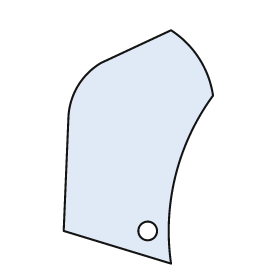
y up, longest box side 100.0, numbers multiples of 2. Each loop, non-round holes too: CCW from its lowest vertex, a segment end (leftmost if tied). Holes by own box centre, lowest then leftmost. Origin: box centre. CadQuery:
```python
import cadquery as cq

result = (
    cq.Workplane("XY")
    .moveTo(14.0, -50.0)
    .threePointArc((16.0, -12.0), (32.0, 22.0))
    .threePointArc((26.0, 38.0), (14.0, 50.0))
    .lineTo(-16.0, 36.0)
    .threePointArc((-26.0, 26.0), (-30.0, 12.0))
    .lineTo(-32.0, -36.0)
    .close()
    .moveTo(4.0, -36.0)
    .circle(4.0)
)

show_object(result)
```